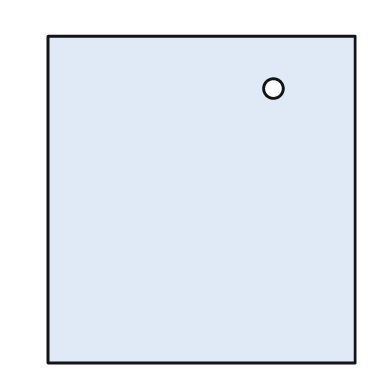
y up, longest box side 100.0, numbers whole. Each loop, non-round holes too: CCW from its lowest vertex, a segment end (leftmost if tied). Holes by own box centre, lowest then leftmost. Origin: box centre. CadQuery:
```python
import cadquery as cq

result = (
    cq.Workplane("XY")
    .moveTo(-47.0, -50.0)
    .lineTo(47.0, -50.0)
    .lineTo(47.0, 50.0)
    .lineTo(-47.0, 50.0)
    .close()
    .moveTo(22.0, 34.0)
    .circle(3.0)
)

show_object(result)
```